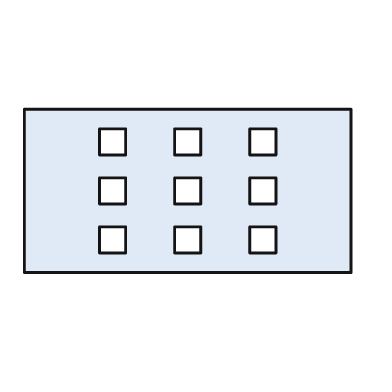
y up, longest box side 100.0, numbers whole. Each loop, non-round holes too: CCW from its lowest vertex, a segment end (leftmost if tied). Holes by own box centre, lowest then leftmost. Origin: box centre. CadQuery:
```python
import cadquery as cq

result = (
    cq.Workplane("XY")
    .moveTo(-50.0, -25.0)
    .lineTo(50.0, -25.0)
    .lineTo(50.0, 25.0)
    .lineTo(-50.0, 25.0)
    .close()
    .moveTo(-27.0, -19.0)
    .lineTo(-19.0, -19.0)
    .lineTo(-19.0, -11.0)
    .lineTo(-27.0, -11.0)
    .close()
    .moveTo(-4.0, -19.0)
    .lineTo(4.0, -19.0)
    .lineTo(4.0, -11.0)
    .lineTo(-4.0, -11.0)
    .close()
    .moveTo(19.0, -19.0)
    .lineTo(27.0, -19.0)
    .lineTo(27.0, -11.0)
    .lineTo(19.0, -11.0)
    .close()
    .moveTo(-27.0, -4.0)
    .lineTo(-19.0, -4.0)
    .lineTo(-19.0, 4.0)
    .lineTo(-27.0, 4.0)
    .close()
    .moveTo(-4.0, -4.0)
    .lineTo(4.0, -4.0)
    .lineTo(4.0, 4.0)
    .lineTo(-4.0, 4.0)
    .close()
    .moveTo(19.0, -4.0)
    .lineTo(27.0, -4.0)
    .lineTo(27.0, 4.0)
    .lineTo(19.0, 4.0)
    .close()
    .moveTo(-27.0, 11.0)
    .lineTo(-19.0, 11.0)
    .lineTo(-19.0, 19.0)
    .lineTo(-27.0, 19.0)
    .close()
    .moveTo(-4.0, 11.0)
    .lineTo(4.0, 11.0)
    .lineTo(4.0, 19.0)
    .lineTo(-4.0, 19.0)
    .close()
    .moveTo(19.0, 11.0)
    .lineTo(27.0, 11.0)
    .lineTo(27.0, 19.0)
    .lineTo(19.0, 19.0)
    .close()
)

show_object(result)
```